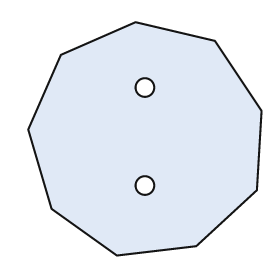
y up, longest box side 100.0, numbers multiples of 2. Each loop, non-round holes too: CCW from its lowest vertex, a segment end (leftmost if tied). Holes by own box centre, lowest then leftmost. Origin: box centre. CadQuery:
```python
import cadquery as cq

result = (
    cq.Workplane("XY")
    .moveTo(-12.0, -50.0)
    .lineTo(22.0, -46.0)
    .lineTo(48.0, -22.0)
    .lineTo(50.0, 12.0)
    .lineTo(30.0, 42.0)
    .lineTo(-4.0, 50.0)
    .lineTo(-36.0, 36.0)
    .lineTo(-50.0, 4.0)
    .lineTo(-40.0, -30.0)
    .close()
    .moveTo(0.0, -20.0)
    .circle(4.0)
    .moveTo(0.0, 22.0)
    .circle(4.0)
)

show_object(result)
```